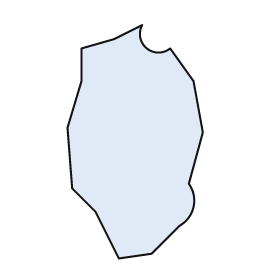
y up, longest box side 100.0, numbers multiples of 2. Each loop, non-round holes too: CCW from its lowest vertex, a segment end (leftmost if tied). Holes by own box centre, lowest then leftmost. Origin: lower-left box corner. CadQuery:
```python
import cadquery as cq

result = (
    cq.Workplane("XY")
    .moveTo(22.0, 0.0)
    .lineTo(36.0, 2.0)
    .lineTo(48.0, 14.0)
    .threePointArc((54.0, 22.0), (52.0, 32.0))
    .lineTo(58.0, 54.0)
    .lineTo(54.0, 76.0)
    .lineTo(44.0, 90.0)
    .threePointArc((34.0, 90.0), (32.0, 100.0))
    .lineTo(20.0, 94.0)
    .lineTo(6.0, 90.0)
    .lineTo(6.0, 76.0)
    .lineTo(0.0, 56.0)
    .lineTo(2.0, 30.0)
    .lineTo(12.0, 20.0)
    .close()
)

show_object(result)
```